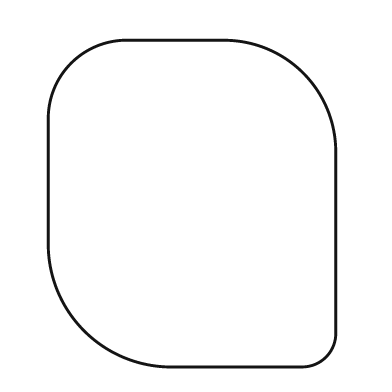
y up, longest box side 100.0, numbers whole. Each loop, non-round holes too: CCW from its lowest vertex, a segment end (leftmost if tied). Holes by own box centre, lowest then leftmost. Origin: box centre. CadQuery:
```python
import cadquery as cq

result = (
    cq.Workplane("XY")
    .moveTo(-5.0, -50.0)
    .lineTo(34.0, -50.0)
    .threePointArc((41.0, -47.0), (44.0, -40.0))
    .lineTo(44.0, 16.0)
    .threePointArc((34.0, 40.0), (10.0, 50.0))
    .lineTo(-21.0, 50.0)
    .threePointArc((-37.0, 43.0), (-44.0, 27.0))
    .lineTo(-44.0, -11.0)
    .threePointArc((-33.0, -39.0), (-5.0, -50.0))
    .close()
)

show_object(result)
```